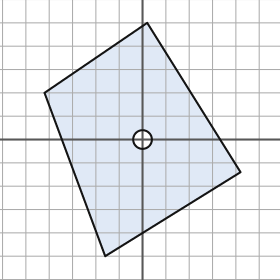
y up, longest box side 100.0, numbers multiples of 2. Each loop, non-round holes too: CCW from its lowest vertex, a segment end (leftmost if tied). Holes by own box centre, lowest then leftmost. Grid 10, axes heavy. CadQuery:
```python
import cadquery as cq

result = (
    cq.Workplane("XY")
    .moveTo(-16.0, -50.0)
    .lineTo(42.0, -14.0)
    .lineTo(2.0, 50.0)
    .lineTo(-42.0, 20.0)
    .close()
    .moveTo(0.0, 0.0)
    .circle(4.0)
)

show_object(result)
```